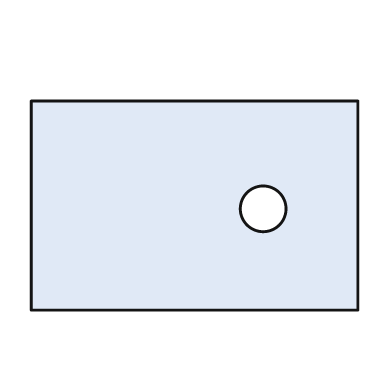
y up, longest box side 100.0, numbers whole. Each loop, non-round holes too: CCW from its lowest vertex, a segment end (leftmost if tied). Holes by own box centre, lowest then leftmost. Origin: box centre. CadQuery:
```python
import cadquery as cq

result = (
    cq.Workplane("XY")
    .moveTo(-50.0, -32.0)
    .lineTo(50.0, -32.0)
    .lineTo(50.0, 32.0)
    .lineTo(-50.0, 32.0)
    .close()
    .moveTo(21.0, -1.0)
    .circle(7.0)
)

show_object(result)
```